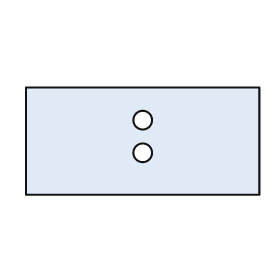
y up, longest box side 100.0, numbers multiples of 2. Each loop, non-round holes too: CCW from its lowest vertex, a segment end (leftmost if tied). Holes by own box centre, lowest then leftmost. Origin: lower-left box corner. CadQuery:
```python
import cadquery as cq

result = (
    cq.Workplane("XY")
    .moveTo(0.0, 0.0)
    .lineTo(100.0, 0.0)
    .lineTo(100.0, 46.0)
    .lineTo(0.0, 46.0)
    .close()
    .moveTo(50.0, 18.0)
    .circle(4.0)
    .moveTo(50.0, 32.0)
    .circle(4.0)
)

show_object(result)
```